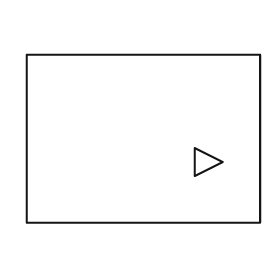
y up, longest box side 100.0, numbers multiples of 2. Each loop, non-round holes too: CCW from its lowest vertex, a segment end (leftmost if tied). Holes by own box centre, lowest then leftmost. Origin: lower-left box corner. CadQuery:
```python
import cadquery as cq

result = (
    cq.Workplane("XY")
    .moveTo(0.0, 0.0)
    .lineTo(100.0, 0.0)
    .lineTo(100.0, 72.0)
    .lineTo(0.0, 72.0)
    .close()
    .moveTo(72.0, 20.0)
    .lineTo(84.0, 26.0)
    .lineTo(72.0, 32.0)
    .close()
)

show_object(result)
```